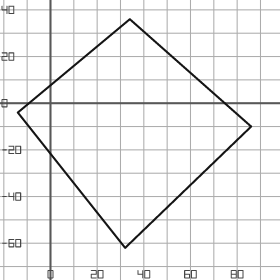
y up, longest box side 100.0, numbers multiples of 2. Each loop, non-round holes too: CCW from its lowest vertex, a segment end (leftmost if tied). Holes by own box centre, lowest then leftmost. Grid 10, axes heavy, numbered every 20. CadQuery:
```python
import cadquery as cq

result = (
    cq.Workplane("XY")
    .moveTo(32.0, -62.0)
    .lineTo(86.0, -10.0)
    .lineTo(34.0, 36.0)
    .lineTo(-14.0, -4.0)
    .close()
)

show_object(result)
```